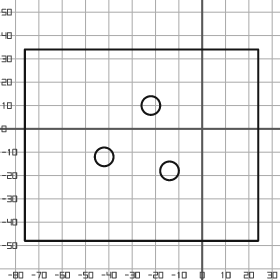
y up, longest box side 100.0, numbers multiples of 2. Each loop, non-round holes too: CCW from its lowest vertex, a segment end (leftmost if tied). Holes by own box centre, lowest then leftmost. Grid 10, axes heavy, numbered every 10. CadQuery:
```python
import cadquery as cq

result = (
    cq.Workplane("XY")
    .moveTo(-76.0, -48.0)
    .lineTo(24.0, -48.0)
    .lineTo(24.0, 34.0)
    .lineTo(-76.0, 34.0)
    .close()
    .moveTo(-14.0, -18.0)
    .circle(4.0)
    .moveTo(-42.0, -12.0)
    .circle(4.0)
    .moveTo(-22.0, 10.0)
    .circle(4.0)
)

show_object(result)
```